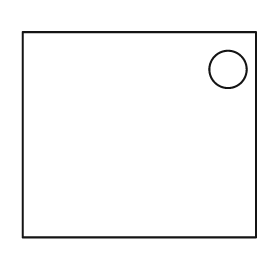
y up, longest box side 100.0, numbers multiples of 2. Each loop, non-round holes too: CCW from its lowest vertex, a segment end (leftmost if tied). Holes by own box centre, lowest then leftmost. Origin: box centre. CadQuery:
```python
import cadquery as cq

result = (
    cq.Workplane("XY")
    .moveTo(-50.0, -44.0)
    .lineTo(50.0, -44.0)
    .lineTo(50.0, 44.0)
    .lineTo(-50.0, 44.0)
    .close()
    .moveTo(38.0, 28.0)
    .circle(8.0)
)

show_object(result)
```